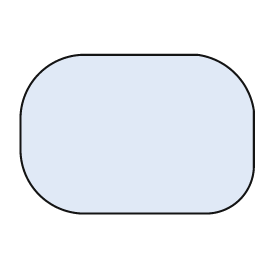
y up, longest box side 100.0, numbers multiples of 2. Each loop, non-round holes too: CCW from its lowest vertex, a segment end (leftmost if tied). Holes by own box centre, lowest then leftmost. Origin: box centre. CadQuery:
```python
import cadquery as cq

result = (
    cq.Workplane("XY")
    .moveTo(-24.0, -34.0)
    .lineTo(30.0, -34.0)
    .threePointArc((44.0, -28.0), (50.0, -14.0))
    .lineTo(50.0, 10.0)
    .threePointArc((42.0, 26.0), (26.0, 34.0))
    .lineTo(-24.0, 34.0)
    .threePointArc((-42.0, 26.0), (-50.0, 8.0))
    .lineTo(-50.0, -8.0)
    .threePointArc((-42.0, -26.0), (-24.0, -34.0))
    .close()
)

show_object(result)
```